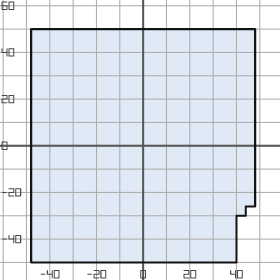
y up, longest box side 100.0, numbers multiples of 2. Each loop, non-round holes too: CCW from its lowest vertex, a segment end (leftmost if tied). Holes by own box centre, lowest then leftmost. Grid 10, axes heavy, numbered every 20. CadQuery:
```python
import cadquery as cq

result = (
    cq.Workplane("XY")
    .moveTo(-48.0, -50.0)
    .lineTo(40.0, -50.0)
    .lineTo(40.0, -30.0)
    .lineTo(44.0, -30.0)
    .lineTo(44.0, -26.0)
    .lineTo(48.0, -26.0)
    .lineTo(48.0, 50.0)
    .lineTo(-48.0, 50.0)
    .close()
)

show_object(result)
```